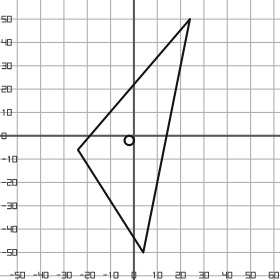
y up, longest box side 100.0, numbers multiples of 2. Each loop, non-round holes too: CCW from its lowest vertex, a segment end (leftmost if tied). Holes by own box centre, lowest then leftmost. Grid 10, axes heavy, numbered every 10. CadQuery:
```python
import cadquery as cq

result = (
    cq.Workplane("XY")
    .moveTo(4.0, -50.0)
    .lineTo(24.0, 50.0)
    .lineTo(-24.0, -6.0)
    .close()
    .moveTo(-2.0, -2.0)
    .circle(2.0)
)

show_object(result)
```